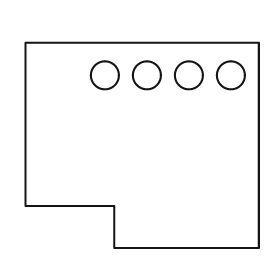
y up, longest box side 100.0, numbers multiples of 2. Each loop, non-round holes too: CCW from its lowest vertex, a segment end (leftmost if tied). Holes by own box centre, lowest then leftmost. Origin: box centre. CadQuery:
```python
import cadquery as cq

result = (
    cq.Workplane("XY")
    .moveTo(-12.0, -44.0)
    .lineTo(50.0, -44.0)
    .lineTo(50.0, 44.0)
    .lineTo(-50.0, 44.0)
    .lineTo(-50.0, -26.0)
    .lineTo(-12.0, -26.0)
    .close()
    .moveTo(-16.0, 30.0)
    .circle(6.0)
    .moveTo(2.0, 30.0)
    .circle(6.0)
    .moveTo(20.0, 30.0)
    .circle(6.0)
    .moveTo(38.0, 30.0)
    .circle(6.0)
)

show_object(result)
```